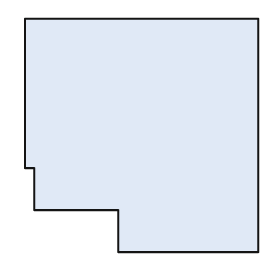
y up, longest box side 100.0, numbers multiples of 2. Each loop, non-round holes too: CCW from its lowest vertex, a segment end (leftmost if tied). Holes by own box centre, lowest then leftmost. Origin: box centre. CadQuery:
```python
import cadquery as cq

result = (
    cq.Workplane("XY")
    .moveTo(-10.0, -50.0)
    .lineTo(50.0, -50.0)
    .lineTo(50.0, 50.0)
    .lineTo(-50.0, 50.0)
    .lineTo(-50.0, -14.0)
    .lineTo(-46.0, -14.0)
    .lineTo(-46.0, -32.0)
    .lineTo(-10.0, -32.0)
    .close()
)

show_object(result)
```